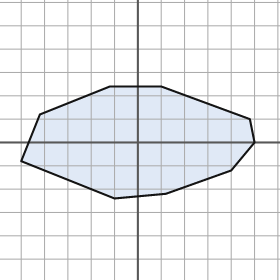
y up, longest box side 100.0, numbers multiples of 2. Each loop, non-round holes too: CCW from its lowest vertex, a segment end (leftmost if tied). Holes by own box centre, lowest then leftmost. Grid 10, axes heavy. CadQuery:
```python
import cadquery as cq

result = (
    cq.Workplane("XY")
    .moveTo(-10.0, -24.0)
    .lineTo(12.0, -22.0)
    .lineTo(40.0, -12.0)
    .lineTo(50.0, 0.0)
    .lineTo(48.0, 10.0)
    .lineTo(10.0, 24.0)
    .lineTo(-12.0, 24.0)
    .lineTo(-42.0, 12.0)
    .lineTo(-50.0, -8.0)
    .close()
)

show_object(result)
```